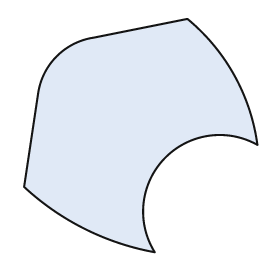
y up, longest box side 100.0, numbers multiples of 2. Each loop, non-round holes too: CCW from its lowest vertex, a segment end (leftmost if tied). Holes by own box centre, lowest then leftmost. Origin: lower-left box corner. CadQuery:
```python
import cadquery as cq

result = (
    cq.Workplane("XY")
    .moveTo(56.0, 0.0)
    .threePointArc((60.0, 40.0), (100.0, 46.0))
    .threePointArc((90.0, 76.0), (70.0, 100.0))
    .lineTo(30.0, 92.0)
    .threePointArc((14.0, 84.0), (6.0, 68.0))
    .lineTo(0.0, 28.0)
    .threePointArc((26.0, 10.0), (56.0, 0.0))
    .close()
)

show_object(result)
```